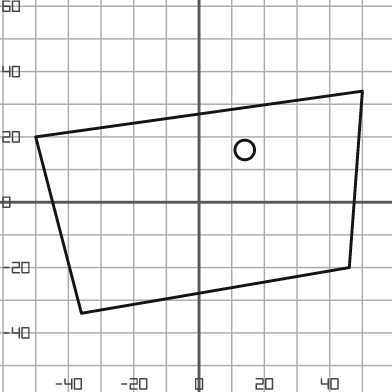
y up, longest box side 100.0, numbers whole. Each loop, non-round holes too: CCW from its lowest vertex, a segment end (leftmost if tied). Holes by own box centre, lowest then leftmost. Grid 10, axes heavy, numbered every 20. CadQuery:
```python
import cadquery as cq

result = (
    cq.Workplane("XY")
    .moveTo(-36.0, -34.0)
    .lineTo(46.0, -20.0)
    .lineTo(50.0, 34.0)
    .lineTo(-50.0, 20.0)
    .close()
    .moveTo(14.0, 16.0)
    .circle(3.0)
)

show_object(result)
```